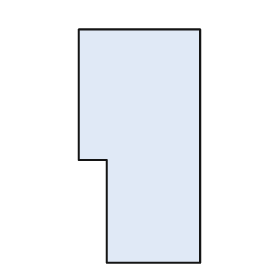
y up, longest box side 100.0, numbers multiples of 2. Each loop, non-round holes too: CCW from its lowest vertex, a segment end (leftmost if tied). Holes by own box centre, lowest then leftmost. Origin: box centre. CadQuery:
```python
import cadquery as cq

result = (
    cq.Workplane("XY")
    .moveTo(-14.0, -50.0)
    .lineTo(26.0, -50.0)
    .lineTo(26.0, 50.0)
    .lineTo(-26.0, 50.0)
    .lineTo(-26.0, -6.0)
    .lineTo(-14.0, -6.0)
    .close()
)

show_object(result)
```